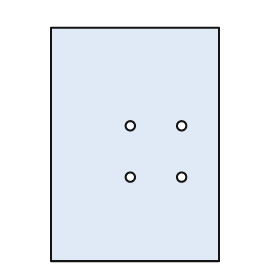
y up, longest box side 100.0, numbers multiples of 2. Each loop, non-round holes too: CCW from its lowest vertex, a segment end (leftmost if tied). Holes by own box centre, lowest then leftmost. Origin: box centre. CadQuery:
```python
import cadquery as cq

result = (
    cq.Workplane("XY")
    .moveTo(-36.0, -50.0)
    .lineTo(36.0, -50.0)
    .lineTo(36.0, 50.0)
    .lineTo(-36.0, 50.0)
    .close()
    .moveTo(-2.0, -14.0)
    .circle(2.0)
    .moveTo(20.0, -14.0)
    .circle(2.0)
    .moveTo(-2.0, 8.0)
    .circle(2.0)
    .moveTo(20.0, 8.0)
    .circle(2.0)
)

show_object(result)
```